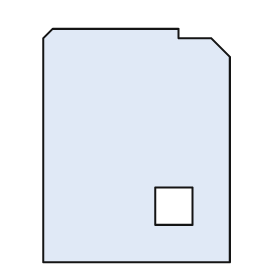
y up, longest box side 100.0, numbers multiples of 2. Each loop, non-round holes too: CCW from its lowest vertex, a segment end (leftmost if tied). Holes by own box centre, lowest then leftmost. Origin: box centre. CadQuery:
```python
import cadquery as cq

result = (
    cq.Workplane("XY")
    .moveTo(-40.0, -50.0)
    .lineTo(40.0, -50.0)
    .lineTo(40.0, 38.0)
    .lineTo(32.0, 46.0)
    .lineTo(18.0, 46.0)
    .lineTo(18.0, 50.0)
    .lineTo(-36.0, 50.0)
    .lineTo(-40.0, 46.0)
    .close()
    .moveTo(8.0, -34.0)
    .lineTo(24.0, -34.0)
    .lineTo(24.0, -18.0)
    .lineTo(8.0, -18.0)
    .close()
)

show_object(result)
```